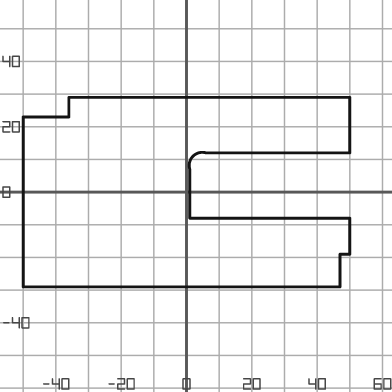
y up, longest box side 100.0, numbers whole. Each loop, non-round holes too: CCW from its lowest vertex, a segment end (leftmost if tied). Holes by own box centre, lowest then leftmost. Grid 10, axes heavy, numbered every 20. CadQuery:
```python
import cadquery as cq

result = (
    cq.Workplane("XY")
    .moveTo(-50.0, -29.0)
    .lineTo(47.0, -29.0)
    .lineTo(47.0, -19.0)
    .lineTo(50.0, -19.0)
    .lineTo(50.0, -8.0)
    .lineTo(1.0, -8.0)
    .lineTo(1.0, 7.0)
    .threePointArc((2.0, 11.0), (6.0, 12.0))
    .lineTo(50.0, 12.0)
    .lineTo(50.0, 29.0)
    .lineTo(-36.0, 29.0)
    .lineTo(-36.0, 23.0)
    .lineTo(-50.0, 23.0)
    .close()
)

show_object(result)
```